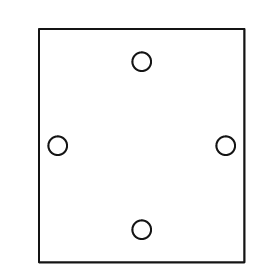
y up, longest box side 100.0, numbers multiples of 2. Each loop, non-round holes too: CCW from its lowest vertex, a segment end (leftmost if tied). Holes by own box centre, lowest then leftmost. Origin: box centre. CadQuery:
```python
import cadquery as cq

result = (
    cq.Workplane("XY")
    .moveTo(-44.0, -50.0)
    .lineTo(44.0, -50.0)
    .lineTo(44.0, 50.0)
    .lineTo(-44.0, 50.0)
    .close()
    .moveTo(0.0, -36.0)
    .circle(4.0)
    .moveTo(-36.0, 0.0)
    .circle(4.0)
    .moveTo(36.0, 0.0)
    .circle(4.0)
    .moveTo(0.0, 36.0)
    .circle(4.0)
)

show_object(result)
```